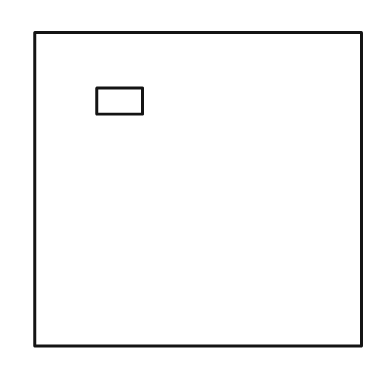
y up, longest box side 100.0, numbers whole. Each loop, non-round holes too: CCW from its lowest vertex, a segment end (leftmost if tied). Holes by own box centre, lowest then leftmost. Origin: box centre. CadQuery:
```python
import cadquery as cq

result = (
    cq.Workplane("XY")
    .moveTo(-50.0, -48.0)
    .lineTo(50.0, -48.0)
    .lineTo(50.0, 48.0)
    .lineTo(-50.0, 48.0)
    .close()
    .moveTo(-31.0, 23.0)
    .lineTo(-17.0, 23.0)
    .lineTo(-17.0, 31.0)
    .lineTo(-31.0, 31.0)
    .close()
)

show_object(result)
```